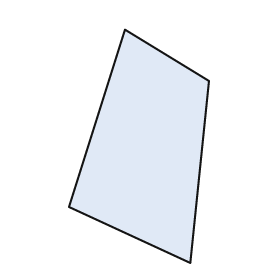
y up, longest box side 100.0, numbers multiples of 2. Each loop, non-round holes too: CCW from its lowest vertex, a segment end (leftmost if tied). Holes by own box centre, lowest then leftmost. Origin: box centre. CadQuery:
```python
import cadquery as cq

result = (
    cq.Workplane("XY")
    .moveTo(22.0, -50.0)
    .lineTo(30.0, 28.0)
    .lineTo(-6.0, 50.0)
    .lineTo(-30.0, -26.0)
    .close()
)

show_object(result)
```